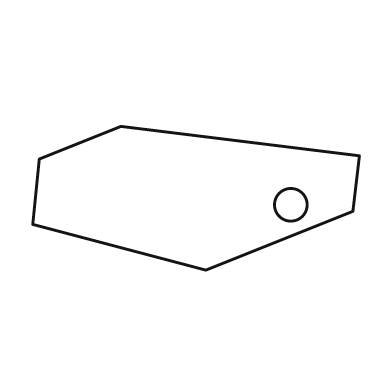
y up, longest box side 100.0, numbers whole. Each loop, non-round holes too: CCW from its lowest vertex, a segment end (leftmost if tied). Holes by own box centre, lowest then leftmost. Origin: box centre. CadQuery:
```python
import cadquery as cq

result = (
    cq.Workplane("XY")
    .moveTo(3.0, -22.0)
    .lineTo(48.0, -4.0)
    .lineTo(50.0, 13.0)
    .lineTo(-23.0, 22.0)
    .lineTo(-48.0, 12.0)
    .lineTo(-50.0, -8.0)
    .close()
    .moveTo(29.0, -2.0)
    .circle(5.0)
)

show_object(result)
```